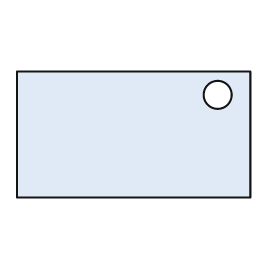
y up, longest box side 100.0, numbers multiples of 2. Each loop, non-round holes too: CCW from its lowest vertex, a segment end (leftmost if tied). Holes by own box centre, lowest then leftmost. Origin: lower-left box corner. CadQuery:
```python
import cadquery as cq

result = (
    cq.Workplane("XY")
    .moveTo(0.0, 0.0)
    .lineTo(100.0, 0.0)
    .lineTo(100.0, 54.0)
    .lineTo(0.0, 54.0)
    .close()
    .moveTo(86.0, 44.0)
    .circle(6.0)
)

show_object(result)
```